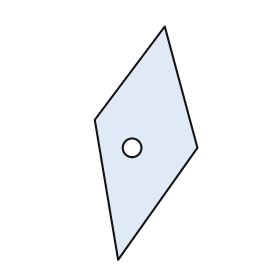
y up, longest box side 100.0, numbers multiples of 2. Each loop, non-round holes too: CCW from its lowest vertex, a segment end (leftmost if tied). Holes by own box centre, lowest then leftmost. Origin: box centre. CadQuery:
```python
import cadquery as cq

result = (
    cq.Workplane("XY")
    .moveTo(-12.0, -50.0)
    .lineTo(22.0, -2.0)
    .lineTo(8.0, 50.0)
    .lineTo(-22.0, 10.0)
    .close()
    .moveTo(-6.0, -2.0)
    .circle(4.0)
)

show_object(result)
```